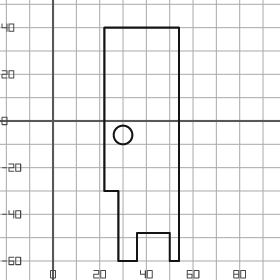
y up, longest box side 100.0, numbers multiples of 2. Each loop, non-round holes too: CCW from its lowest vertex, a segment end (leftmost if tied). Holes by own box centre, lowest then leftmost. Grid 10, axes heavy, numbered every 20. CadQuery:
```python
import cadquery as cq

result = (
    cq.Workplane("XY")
    .moveTo(28.0, -60.0)
    .lineTo(36.0, -60.0)
    .lineTo(36.0, -48.0)
    .lineTo(50.0, -48.0)
    .lineTo(50.0, -60.0)
    .lineTo(54.0, -60.0)
    .lineTo(54.0, 40.0)
    .lineTo(22.0, 40.0)
    .lineTo(22.0, -30.0)
    .lineTo(28.0, -30.0)
    .close()
    .moveTo(30.0, -6.0)
    .circle(4.0)
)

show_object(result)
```